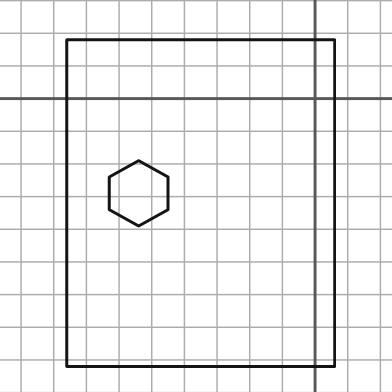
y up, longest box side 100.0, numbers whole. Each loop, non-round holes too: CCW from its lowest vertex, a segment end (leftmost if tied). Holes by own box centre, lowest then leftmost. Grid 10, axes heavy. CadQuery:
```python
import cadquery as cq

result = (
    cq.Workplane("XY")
    .moveTo(-76.0, -82.0)
    .lineTo(6.0, -82.0)
    .lineTo(6.0, 18.0)
    .lineTo(-76.0, 18.0)
    .close()
    .moveTo(-54.0, -39.0)
    .lineTo(-45.0, -34.0)
    .lineTo(-45.0, -24.0)
    .lineTo(-54.0, -19.0)
    .lineTo(-63.0, -24.0)
    .lineTo(-63.0, -34.0)
    .close()
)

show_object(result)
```